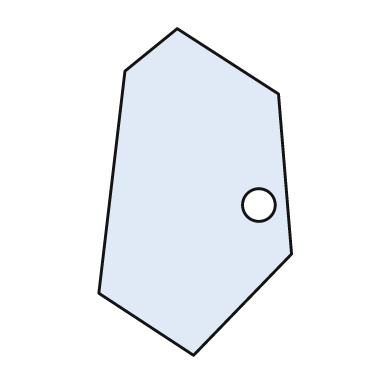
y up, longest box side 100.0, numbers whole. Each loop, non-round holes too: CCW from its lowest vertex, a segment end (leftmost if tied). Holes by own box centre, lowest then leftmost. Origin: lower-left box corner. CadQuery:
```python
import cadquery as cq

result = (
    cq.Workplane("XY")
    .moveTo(29.0, 0.0)
    .lineTo(59.0, 31.0)
    .lineTo(55.0, 80.0)
    .lineTo(24.0, 100.0)
    .lineTo(8.0, 87.0)
    .lineTo(0.0, 19.0)
    .close()
    .moveTo(49.0, 46.0)
    .circle(5.0)
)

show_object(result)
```